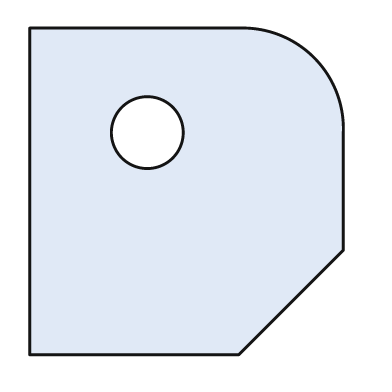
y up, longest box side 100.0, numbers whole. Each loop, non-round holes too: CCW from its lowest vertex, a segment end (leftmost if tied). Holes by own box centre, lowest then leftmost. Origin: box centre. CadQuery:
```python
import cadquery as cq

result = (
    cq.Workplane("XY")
    .moveTo(-48.0, -50.0)
    .lineTo(16.0, -50.0)
    .lineTo(48.0, -18.0)
    .lineTo(48.0, 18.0)
    .threePointArc((39.0, 41.0), (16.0, 50.0))
    .lineTo(-48.0, 50.0)
    .close()
    .moveTo(-12.0, 18.0)
    .circle(11.0)
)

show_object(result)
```